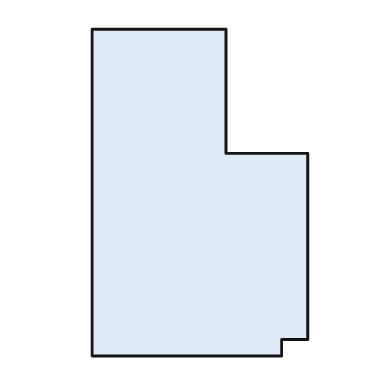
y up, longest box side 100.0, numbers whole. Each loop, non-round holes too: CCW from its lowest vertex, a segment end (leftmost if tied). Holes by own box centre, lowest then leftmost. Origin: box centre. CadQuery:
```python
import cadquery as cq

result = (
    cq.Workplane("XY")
    .moveTo(-33.0, -50.0)
    .lineTo(25.0, -50.0)
    .lineTo(25.0, -45.0)
    .lineTo(33.0, -45.0)
    .lineTo(33.0, 12.0)
    .lineTo(8.0, 12.0)
    .lineTo(8.0, 50.0)
    .lineTo(-33.0, 50.0)
    .close()
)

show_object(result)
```